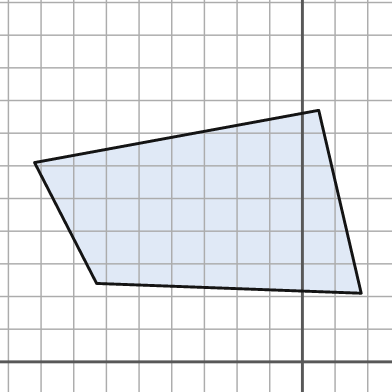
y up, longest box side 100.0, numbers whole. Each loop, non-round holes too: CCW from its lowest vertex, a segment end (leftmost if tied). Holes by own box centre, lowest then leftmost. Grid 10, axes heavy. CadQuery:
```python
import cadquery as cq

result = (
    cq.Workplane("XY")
    .moveTo(18.0, 21.0)
    .lineTo(5.0, 77.0)
    .lineTo(-82.0, 61.0)
    .lineTo(-63.0, 24.0)
    .close()
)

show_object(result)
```